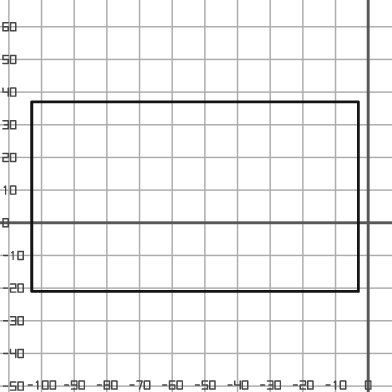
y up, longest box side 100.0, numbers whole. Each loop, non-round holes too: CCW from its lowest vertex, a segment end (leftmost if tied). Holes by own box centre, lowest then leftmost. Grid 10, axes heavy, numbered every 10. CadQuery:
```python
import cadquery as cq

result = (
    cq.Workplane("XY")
    .moveTo(-103.0, -21.0)
    .lineTo(-3.0, -21.0)
    .lineTo(-3.0, 37.0)
    .lineTo(-103.0, 37.0)
    .close()
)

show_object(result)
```